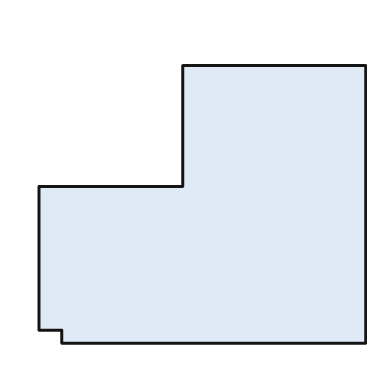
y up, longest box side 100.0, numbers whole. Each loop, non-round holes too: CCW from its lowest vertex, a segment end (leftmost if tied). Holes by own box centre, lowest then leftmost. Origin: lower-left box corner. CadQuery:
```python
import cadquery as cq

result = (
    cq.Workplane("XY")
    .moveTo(7.0, 0.0)
    .lineTo(100.0, 0.0)
    .lineTo(100.0, 85.0)
    .lineTo(44.0, 85.0)
    .lineTo(44.0, 48.0)
    .lineTo(0.0, 48.0)
    .lineTo(0.0, 4.0)
    .lineTo(7.0, 4.0)
    .close()
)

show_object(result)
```